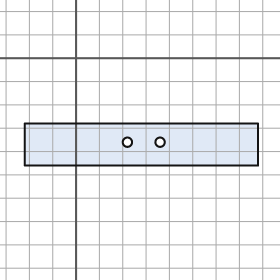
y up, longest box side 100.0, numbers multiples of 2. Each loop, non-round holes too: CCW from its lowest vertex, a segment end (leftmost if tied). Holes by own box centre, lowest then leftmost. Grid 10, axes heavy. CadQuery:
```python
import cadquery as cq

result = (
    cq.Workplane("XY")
    .moveTo(-22.0, -46.0)
    .lineTo(78.0, -46.0)
    .lineTo(78.0, -28.0)
    .lineTo(-22.0, -28.0)
    .close()
    .moveTo(22.0, -36.0)
    .circle(2.0)
    .moveTo(36.0, -36.0)
    .circle(2.0)
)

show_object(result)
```